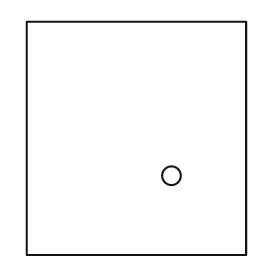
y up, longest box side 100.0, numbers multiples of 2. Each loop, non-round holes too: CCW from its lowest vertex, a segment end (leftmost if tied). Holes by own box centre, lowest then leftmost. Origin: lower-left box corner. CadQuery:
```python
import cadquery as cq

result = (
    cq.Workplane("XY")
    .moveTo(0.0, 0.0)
    .lineTo(94.0, 0.0)
    .lineTo(94.0, 100.0)
    .lineTo(0.0, 100.0)
    .close()
    .moveTo(62.0, 34.0)
    .circle(4.0)
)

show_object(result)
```